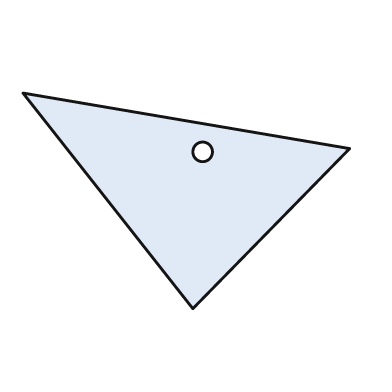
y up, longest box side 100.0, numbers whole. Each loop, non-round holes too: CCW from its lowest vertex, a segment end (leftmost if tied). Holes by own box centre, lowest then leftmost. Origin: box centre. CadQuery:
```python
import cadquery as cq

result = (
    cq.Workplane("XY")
    .moveTo(2.0, -33.0)
    .lineTo(50.0, 16.0)
    .lineTo(-50.0, 33.0)
    .close()
    .moveTo(5.0, 15.0)
    .circle(3.0)
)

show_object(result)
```